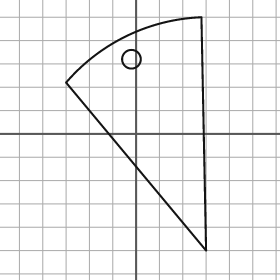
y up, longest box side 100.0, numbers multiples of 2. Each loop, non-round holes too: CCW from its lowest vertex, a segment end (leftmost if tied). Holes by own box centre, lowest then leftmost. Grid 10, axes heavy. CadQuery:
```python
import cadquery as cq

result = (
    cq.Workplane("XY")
    .moveTo(30.0, -50.0)
    .lineTo(28.0, 50.0)
    .threePointArc((-4.0, 42.0), (-30.0, 22.0))
    .close()
    .moveTo(-2.0, 32.0)
    .circle(4.0)
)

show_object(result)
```